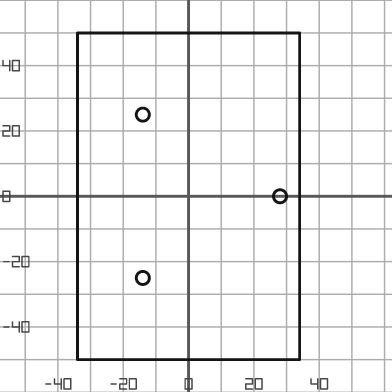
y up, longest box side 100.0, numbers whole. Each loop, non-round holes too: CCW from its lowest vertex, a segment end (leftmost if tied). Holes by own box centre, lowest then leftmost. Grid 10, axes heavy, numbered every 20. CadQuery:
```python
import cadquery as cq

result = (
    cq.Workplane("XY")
    .moveTo(-34.0, -50.0)
    .lineTo(34.0, -50.0)
    .lineTo(34.0, 50.0)
    .lineTo(-34.0, 50.0)
    .close()
    .moveTo(-14.0, -25.0)
    .circle(2.0)
    .moveTo(28.0, 0.0)
    .circle(2.0)
    .moveTo(-14.0, 25.0)
    .circle(2.0)
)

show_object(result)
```